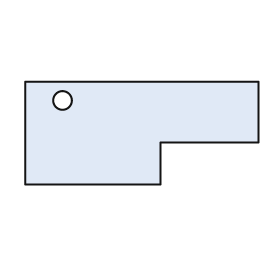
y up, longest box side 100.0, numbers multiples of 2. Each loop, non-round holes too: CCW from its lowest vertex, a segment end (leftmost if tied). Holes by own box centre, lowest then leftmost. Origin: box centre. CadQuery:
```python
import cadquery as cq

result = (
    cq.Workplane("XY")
    .moveTo(-50.0, -22.0)
    .lineTo(8.0, -22.0)
    .lineTo(8.0, -4.0)
    .lineTo(50.0, -4.0)
    .lineTo(50.0, 22.0)
    .lineTo(-50.0, 22.0)
    .close()
    .moveTo(-34.0, 14.0)
    .circle(4.0)
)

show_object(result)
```